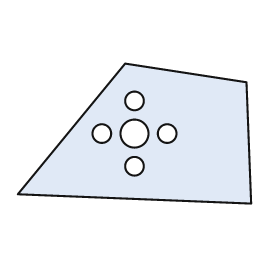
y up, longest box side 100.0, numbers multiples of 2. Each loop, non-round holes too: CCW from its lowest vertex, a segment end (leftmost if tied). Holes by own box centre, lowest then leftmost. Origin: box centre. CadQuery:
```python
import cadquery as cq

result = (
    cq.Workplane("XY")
    .moveTo(50.0, -30.0)
    .lineTo(48.0, 22.0)
    .lineTo(-4.0, 30.0)
    .lineTo(-50.0, -26.0)
    .close()
    .moveTo(0.0, -14.0)
    .circle(4.0)
    .moveTo(-14.0, 0.0)
    .circle(4.0)
    .moveTo(0.0, 0.0)
    .circle(6.0)
    .moveTo(14.0, 0.0)
    .circle(4.0)
    .moveTo(0.0, 14.0)
    .circle(4.0)
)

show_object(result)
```